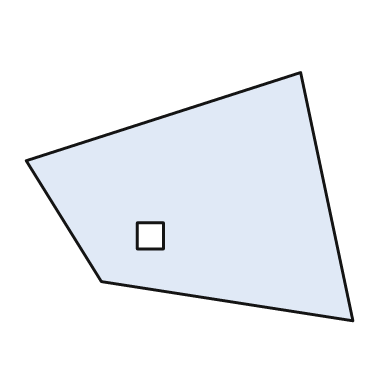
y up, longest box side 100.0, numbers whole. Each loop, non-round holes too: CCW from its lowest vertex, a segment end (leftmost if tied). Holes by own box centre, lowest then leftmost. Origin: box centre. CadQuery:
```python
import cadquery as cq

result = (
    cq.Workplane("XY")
    .moveTo(50.0, -38.0)
    .lineTo(34.0, 38.0)
    .lineTo(-50.0, 11.0)
    .lineTo(-27.0, -26.0)
    .close()
    .moveTo(-16.0, -16.0)
    .lineTo(-8.0, -16.0)
    .lineTo(-8.0, -8.0)
    .lineTo(-16.0, -8.0)
    .close()
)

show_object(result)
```